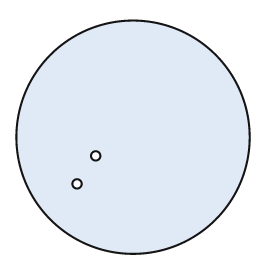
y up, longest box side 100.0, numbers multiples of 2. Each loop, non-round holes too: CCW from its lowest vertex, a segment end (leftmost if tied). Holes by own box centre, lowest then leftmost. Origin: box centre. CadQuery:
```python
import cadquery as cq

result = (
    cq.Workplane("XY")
    .moveTo(0.0, 0.0)
    .circle(50.0)
    .moveTo(-24.0, -20.0)
    .circle(2.0)
    .moveTo(-16.0, -8.0)
    .circle(2.0)
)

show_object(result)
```